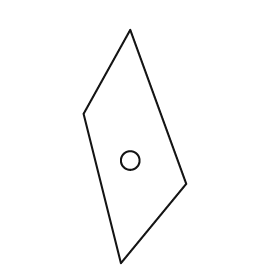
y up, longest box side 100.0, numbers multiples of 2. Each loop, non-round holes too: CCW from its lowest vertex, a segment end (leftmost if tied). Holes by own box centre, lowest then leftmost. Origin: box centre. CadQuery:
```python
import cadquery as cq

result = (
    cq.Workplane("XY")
    .moveTo(-6.0, -50.0)
    .lineTo(22.0, -16.0)
    .lineTo(-2.0, 50.0)
    .lineTo(-22.0, 14.0)
    .close()
    .moveTo(-2.0, -6.0)
    .circle(4.0)
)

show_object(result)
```